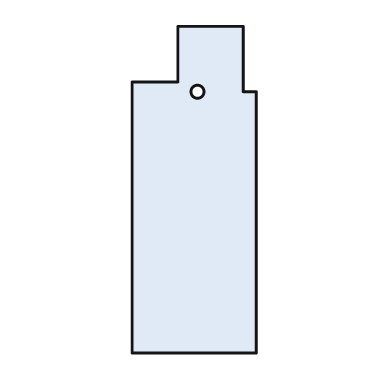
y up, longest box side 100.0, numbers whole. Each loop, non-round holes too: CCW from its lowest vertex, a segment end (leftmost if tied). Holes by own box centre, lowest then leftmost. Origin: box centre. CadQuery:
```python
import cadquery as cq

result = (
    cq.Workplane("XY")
    .moveTo(-19.0, -50.0)
    .lineTo(19.0, -50.0)
    .lineTo(19.0, 30.0)
    .lineTo(15.0, 30.0)
    .lineTo(15.0, 50.0)
    .lineTo(-5.0, 50.0)
    .lineTo(-5.0, 33.0)
    .lineTo(-19.0, 33.0)
    .close()
    .moveTo(1.0, 30.0)
    .circle(2.0)
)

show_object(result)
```